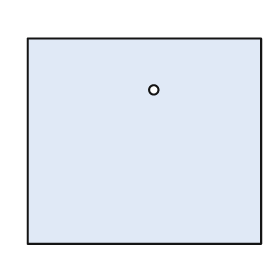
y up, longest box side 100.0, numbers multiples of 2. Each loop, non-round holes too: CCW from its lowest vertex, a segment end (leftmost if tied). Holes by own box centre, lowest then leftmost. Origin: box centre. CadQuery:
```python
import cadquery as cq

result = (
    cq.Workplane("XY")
    .moveTo(-50.0, -44.0)
    .lineTo(50.0, -44.0)
    .lineTo(50.0, 44.0)
    .lineTo(-50.0, 44.0)
    .close()
    .moveTo(4.0, 22.0)
    .circle(2.0)
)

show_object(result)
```